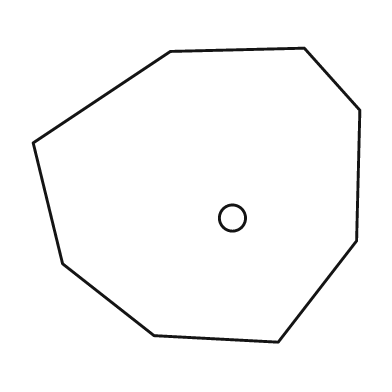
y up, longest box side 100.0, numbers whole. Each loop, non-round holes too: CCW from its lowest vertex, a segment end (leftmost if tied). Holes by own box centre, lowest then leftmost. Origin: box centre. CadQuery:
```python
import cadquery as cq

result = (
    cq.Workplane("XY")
    .moveTo(25.0, -45.0)
    .lineTo(49.0, -14.0)
    .lineTo(50.0, 26.0)
    .lineTo(33.0, 45.0)
    .lineTo(-8.0, 44.0)
    .lineTo(-50.0, 16.0)
    .lineTo(-41.0, -21.0)
    .lineTo(-13.0, -43.0)
    .close()
    .moveTo(11.0, -7.0)
    .circle(4.0)
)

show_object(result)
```